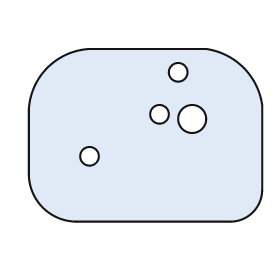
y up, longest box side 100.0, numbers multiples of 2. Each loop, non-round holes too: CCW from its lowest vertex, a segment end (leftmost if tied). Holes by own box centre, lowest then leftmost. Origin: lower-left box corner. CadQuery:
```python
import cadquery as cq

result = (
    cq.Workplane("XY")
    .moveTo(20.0, 0.0)
    .lineTo(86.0, 0.0)
    .threePointArc((96.0, 4.0), (100.0, 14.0))
    .lineTo(100.0, 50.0)
    .threePointArc((92.0, 66.0), (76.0, 74.0))
    .lineTo(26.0, 74.0)
    .threePointArc((8.0, 66.0), (0.0, 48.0))
    .lineTo(0.0, 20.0)
    .threePointArc((6.0, 6.0), (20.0, 0.0))
    .close()
    .moveTo(26.0, 28.0)
    .circle(4.0)
    .moveTo(70.0, 44.0)
    .circle(6.0)
    .moveTo(56.0, 46.0)
    .circle(4.0)
    .moveTo(64.0, 64.0)
    .circle(4.0)
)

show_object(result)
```